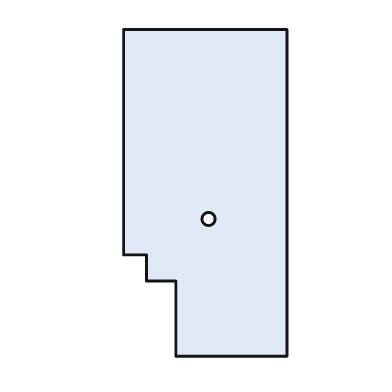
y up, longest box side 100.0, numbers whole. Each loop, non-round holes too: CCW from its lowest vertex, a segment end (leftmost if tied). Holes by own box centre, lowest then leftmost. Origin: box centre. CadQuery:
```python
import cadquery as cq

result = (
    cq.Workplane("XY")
    .moveTo(-9.0, -50.0)
    .lineTo(25.0, -50.0)
    .lineTo(25.0, 50.0)
    .lineTo(-25.0, 50.0)
    .lineTo(-25.0, -19.0)
    .lineTo(-18.0, -19.0)
    .lineTo(-18.0, -27.0)
    .lineTo(-9.0, -27.0)
    .close()
    .moveTo(1.0, -8.0)
    .circle(2.0)
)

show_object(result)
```